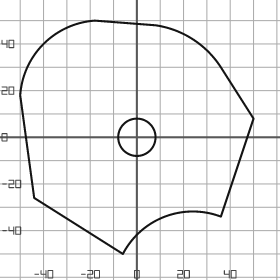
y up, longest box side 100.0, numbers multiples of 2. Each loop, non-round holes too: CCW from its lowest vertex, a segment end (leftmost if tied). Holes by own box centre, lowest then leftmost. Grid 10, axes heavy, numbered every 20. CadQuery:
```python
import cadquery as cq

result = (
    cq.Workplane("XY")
    .moveTo(-6.0, -50.0)
    .threePointArc((12.0, -34.0), (36.0, -34.0))
    .lineTo(50.0, 8.0)
    .lineTo(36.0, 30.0)
    .threePointArc((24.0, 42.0), (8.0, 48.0))
    .lineTo(-18.0, 50.0)
    .threePointArc((-40.0, 40.0), (-50.0, 18.0))
    .lineTo(-44.0, -26.0)
    .close()
    .moveTo(0.0, 0.0)
    .circle(8.0)
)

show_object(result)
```